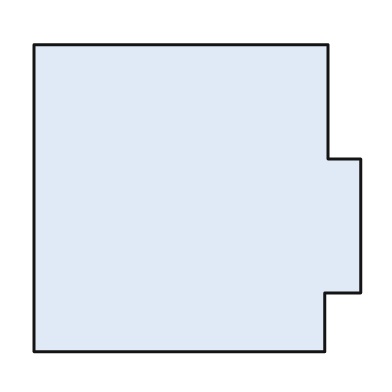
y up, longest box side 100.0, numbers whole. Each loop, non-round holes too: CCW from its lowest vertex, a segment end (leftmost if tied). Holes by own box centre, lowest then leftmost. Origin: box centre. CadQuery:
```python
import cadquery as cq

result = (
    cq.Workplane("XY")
    .moveTo(-50.0, -47.0)
    .lineTo(39.0, -47.0)
    .lineTo(39.0, -29.0)
    .lineTo(50.0, -29.0)
    .lineTo(50.0, 12.0)
    .lineTo(40.0, 12.0)
    .lineTo(40.0, 47.0)
    .lineTo(-50.0, 47.0)
    .close()
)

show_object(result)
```